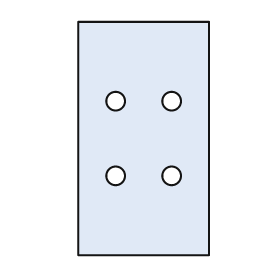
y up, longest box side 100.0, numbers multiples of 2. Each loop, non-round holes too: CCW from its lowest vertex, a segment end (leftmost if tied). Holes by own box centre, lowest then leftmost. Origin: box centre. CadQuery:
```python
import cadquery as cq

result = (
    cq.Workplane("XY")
    .moveTo(-28.0, -50.0)
    .lineTo(28.0, -50.0)
    .lineTo(28.0, 50.0)
    .lineTo(-28.0, 50.0)
    .close()
    .moveTo(-12.0, -16.0)
    .circle(4.0)
    .moveTo(12.0, -16.0)
    .circle(4.0)
    .moveTo(-12.0, 16.0)
    .circle(4.0)
    .moveTo(12.0, 16.0)
    .circle(4.0)
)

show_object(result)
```